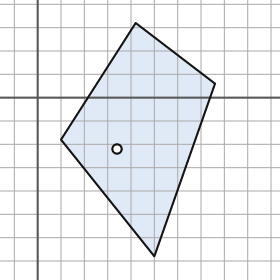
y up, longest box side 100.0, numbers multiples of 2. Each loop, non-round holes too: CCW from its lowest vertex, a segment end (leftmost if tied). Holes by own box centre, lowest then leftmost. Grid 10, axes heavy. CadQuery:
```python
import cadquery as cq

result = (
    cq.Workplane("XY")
    .moveTo(50.0, -68.0)
    .lineTo(76.0, 6.0)
    .lineTo(42.0, 32.0)
    .lineTo(10.0, -18.0)
    .close()
    .moveTo(34.0, -22.0)
    .circle(2.0)
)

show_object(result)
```